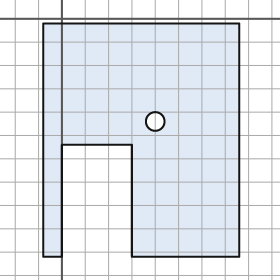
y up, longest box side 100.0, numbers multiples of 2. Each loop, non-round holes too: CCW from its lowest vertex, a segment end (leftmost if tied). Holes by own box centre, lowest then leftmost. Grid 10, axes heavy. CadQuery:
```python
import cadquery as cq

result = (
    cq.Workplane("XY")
    .moveTo(-8.0, -102.0)
    .lineTo(0.0, -102.0)
    .lineTo(0.0, -54.0)
    .lineTo(30.0, -54.0)
    .lineTo(30.0, -102.0)
    .lineTo(76.0, -102.0)
    .lineTo(76.0, -2.0)
    .lineTo(-8.0, -2.0)
    .close()
    .moveTo(40.0, -44.0)
    .circle(4.0)
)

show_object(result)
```